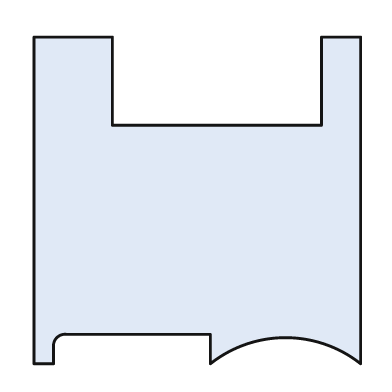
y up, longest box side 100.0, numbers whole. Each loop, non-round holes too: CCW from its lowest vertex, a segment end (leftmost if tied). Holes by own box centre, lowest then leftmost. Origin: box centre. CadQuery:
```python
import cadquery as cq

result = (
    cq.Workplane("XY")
    .moveTo(-50.0, -50.0)
    .lineTo(-44.0, -50.0)
    .lineTo(-44.0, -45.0)
    .threePointArc((-43.0, -42.0), (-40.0, -41.0))
    .lineTo(4.0, -41.0)
    .lineTo(4.0, -50.0)
    .threePointArc((27.0, -42.0), (50.0, -50.0))
    .lineTo(50.0, 50.0)
    .lineTo(38.0, 50.0)
    .lineTo(38.0, 23.0)
    .lineTo(-26.0, 23.0)
    .lineTo(-26.0, 50.0)
    .lineTo(-50.0, 50.0)
    .close()
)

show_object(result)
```